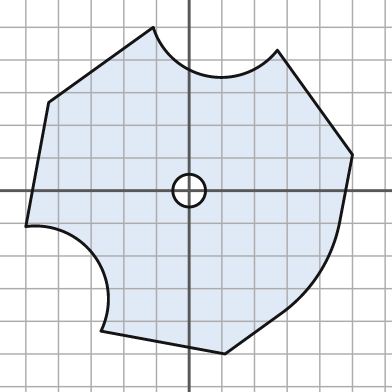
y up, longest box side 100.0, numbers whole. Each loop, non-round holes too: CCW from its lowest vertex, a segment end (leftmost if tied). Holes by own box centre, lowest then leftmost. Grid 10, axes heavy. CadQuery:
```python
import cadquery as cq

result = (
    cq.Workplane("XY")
    .moveTo(11.0, -50.0)
    .lineTo(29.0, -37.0)
    .threePointArc((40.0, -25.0), (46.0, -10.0))
    .lineTo(50.0, 11.0)
    .lineTo(27.0, 43.0)
    .threePointArc((6.0, 35.0), (-11.0, 50.0))
    .lineTo(-43.0, 27.0)
    .lineTo(-50.0, -11.0)
    .threePointArc((-29.0, -20.0), (-27.0, -43.0))
    .close()
    .moveTo(0.0, 0.0)
    .circle(5.0)
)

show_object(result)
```